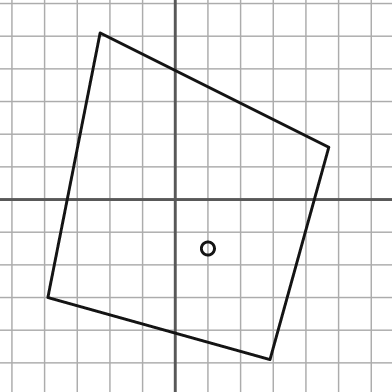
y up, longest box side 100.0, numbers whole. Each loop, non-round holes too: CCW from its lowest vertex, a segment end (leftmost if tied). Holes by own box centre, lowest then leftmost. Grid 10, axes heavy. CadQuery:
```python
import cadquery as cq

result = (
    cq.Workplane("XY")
    .moveTo(29.0, -49.0)
    .lineTo(47.0, 16.0)
    .lineTo(-23.0, 51.0)
    .lineTo(-39.0, -30.0)
    .close()
    .moveTo(10.0, -15.0)
    .circle(2.0)
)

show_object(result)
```